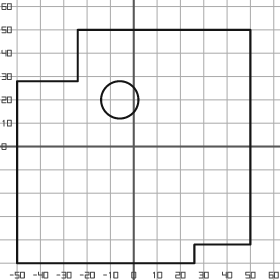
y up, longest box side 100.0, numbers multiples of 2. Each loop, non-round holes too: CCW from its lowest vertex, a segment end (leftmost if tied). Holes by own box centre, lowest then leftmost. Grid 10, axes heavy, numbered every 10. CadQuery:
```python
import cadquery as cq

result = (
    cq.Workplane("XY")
    .moveTo(-50.0, -50.0)
    .lineTo(26.0, -50.0)
    .lineTo(26.0, -42.0)
    .lineTo(50.0, -42.0)
    .lineTo(50.0, 50.0)
    .lineTo(-24.0, 50.0)
    .lineTo(-24.0, 28.0)
    .lineTo(-50.0, 28.0)
    .close()
    .moveTo(-6.0, 20.0)
    .circle(8.0)
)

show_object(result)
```